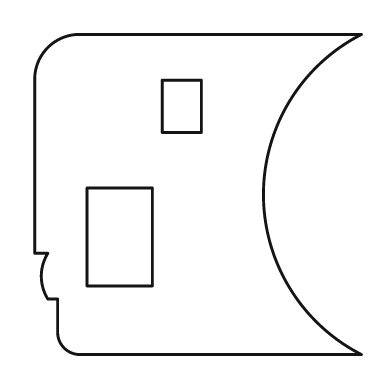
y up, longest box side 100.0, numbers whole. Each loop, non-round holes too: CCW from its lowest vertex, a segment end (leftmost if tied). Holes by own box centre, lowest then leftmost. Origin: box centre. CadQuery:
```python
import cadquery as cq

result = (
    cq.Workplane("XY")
    .moveTo(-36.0, -49.0)
    .lineTo(50.0, -49.0)
    .threePointArc((20.0, 0.0), (50.0, 49.0))
    .lineTo(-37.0, 49.0)
    .threePointArc((-46.0, 45.0), (-50.0, 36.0))
    .lineTo(-50.0, -18.0)
    .lineTo(-46.0, -18.0)
    .threePointArc((-48.0, -25.0), (-46.0, -32.0))
    .lineTo(-43.0, -32.0)
    .lineTo(-43.0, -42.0)
    .threePointArc((-41.0, -47.0), (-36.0, -49.0))
    .close()
    .moveTo(-34.0, -28.0)
    .lineTo(-14.0, -28.0)
    .lineTo(-14.0, 2.0)
    .lineTo(-34.0, 2.0)
    .close()
    .moveTo(-11.0, 19.0)
    .lineTo(1.0, 19.0)
    .lineTo(1.0, 35.0)
    .lineTo(-11.0, 35.0)
    .close()
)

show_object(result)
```